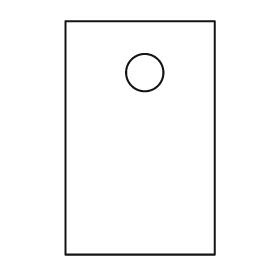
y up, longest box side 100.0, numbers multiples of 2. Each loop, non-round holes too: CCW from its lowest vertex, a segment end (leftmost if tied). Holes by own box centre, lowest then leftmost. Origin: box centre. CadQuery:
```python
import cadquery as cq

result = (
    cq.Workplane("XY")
    .moveTo(-32.0, -50.0)
    .lineTo(32.0, -50.0)
    .lineTo(32.0, 50.0)
    .lineTo(-32.0, 50.0)
    .close()
    .moveTo(2.0, 28.0)
    .circle(8.0)
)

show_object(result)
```